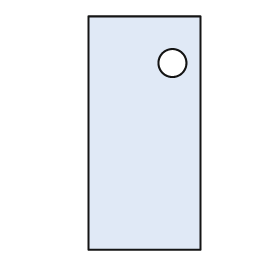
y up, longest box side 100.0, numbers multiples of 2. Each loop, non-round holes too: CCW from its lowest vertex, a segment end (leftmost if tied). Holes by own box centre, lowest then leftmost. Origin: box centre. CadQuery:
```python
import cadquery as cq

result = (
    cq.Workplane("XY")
    .moveTo(-24.0, -50.0)
    .lineTo(24.0, -50.0)
    .lineTo(24.0, 50.0)
    .lineTo(-24.0, 50.0)
    .close()
    .moveTo(12.0, 30.0)
    .circle(6.0)
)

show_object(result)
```